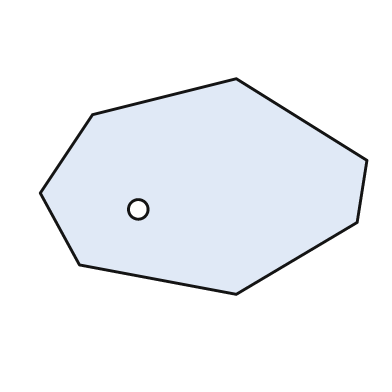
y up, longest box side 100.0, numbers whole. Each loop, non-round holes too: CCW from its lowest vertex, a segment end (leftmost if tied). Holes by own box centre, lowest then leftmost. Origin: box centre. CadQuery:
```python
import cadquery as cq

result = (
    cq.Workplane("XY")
    .moveTo(10.0, -33.0)
    .lineTo(47.0, -11.0)
    .lineTo(50.0, 8.0)
    .lineTo(10.0, 33.0)
    .lineTo(-34.0, 22.0)
    .lineTo(-50.0, -2.0)
    .lineTo(-38.0, -24.0)
    .close()
    .moveTo(-20.0, -7.0)
    .circle(3.0)
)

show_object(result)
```